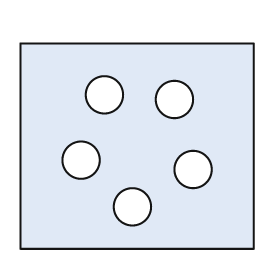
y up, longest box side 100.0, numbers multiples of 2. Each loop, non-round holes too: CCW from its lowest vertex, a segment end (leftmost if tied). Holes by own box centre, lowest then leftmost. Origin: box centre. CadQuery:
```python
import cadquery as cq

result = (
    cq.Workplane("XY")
    .moveTo(-50.0, -44.0)
    .lineTo(50.0, -44.0)
    .lineTo(50.0, 44.0)
    .lineTo(-50.0, 44.0)
    .close()
    .moveTo(-2.0, -26.0)
    .circle(8.0)
    .moveTo(24.0, -10.0)
    .circle(8.0)
    .moveTo(-24.0, -6.0)
    .circle(8.0)
    .moveTo(16.0, 20.0)
    .circle(8.0)
    .moveTo(-14.0, 22.0)
    .circle(8.0)
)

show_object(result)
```